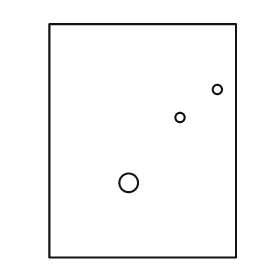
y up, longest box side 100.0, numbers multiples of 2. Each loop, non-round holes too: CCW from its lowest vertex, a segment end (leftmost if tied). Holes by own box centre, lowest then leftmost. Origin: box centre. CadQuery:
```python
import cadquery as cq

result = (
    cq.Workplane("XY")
    .moveTo(-40.0, -50.0)
    .lineTo(40.0, -50.0)
    .lineTo(40.0, 50.0)
    .lineTo(-40.0, 50.0)
    .close()
    .moveTo(-6.0, -18.0)
    .circle(4.0)
    .moveTo(16.0, 10.0)
    .circle(2.0)
    .moveTo(32.0, 22.0)
    .circle(2.0)
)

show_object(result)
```